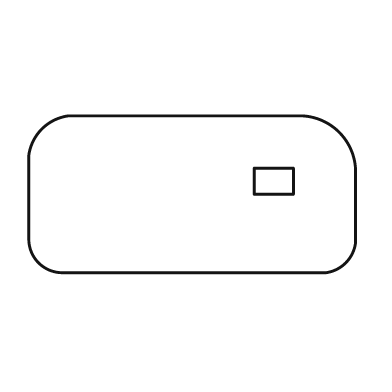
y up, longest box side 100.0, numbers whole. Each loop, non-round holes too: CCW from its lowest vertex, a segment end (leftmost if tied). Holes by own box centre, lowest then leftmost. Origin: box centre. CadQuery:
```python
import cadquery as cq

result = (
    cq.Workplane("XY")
    .moveTo(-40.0, -24.0)
    .lineTo(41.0, -24.0)
    .threePointArc((47.0, -21.0), (50.0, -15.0))
    .lineTo(50.0, 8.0)
    .threePointArc((45.0, 19.0), (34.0, 24.0))
    .lineTo(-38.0, 24.0)
    .threePointArc((-46.0, 20.0), (-50.0, 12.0))
    .lineTo(-50.0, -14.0)
    .threePointArc((-47.0, -21.0), (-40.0, -24.0))
    .close()
    .moveTo(19.0, 0.0)
    .lineTo(31.0, 0.0)
    .lineTo(31.0, 8.0)
    .lineTo(19.0, 8.0)
    .close()
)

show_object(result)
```